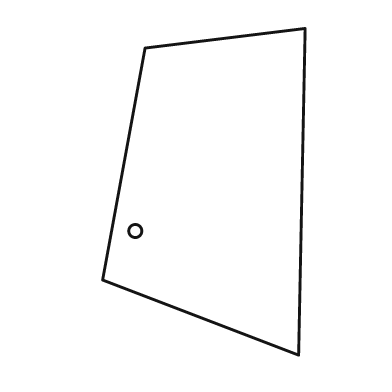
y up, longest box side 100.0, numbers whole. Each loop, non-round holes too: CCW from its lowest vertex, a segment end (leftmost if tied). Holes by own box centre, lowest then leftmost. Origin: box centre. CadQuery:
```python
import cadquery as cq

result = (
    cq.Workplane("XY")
    .moveTo(29.0, -50.0)
    .lineTo(31.0, 50.0)
    .lineTo(-18.0, 44.0)
    .lineTo(-31.0, -27.0)
    .close()
    .moveTo(-21.0, -12.0)
    .circle(2.0)
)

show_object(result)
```